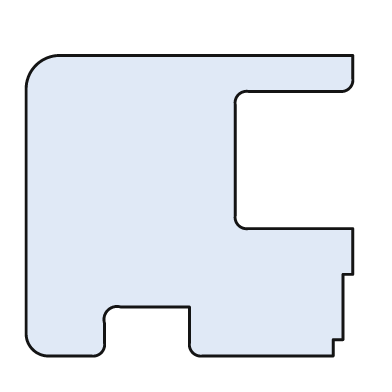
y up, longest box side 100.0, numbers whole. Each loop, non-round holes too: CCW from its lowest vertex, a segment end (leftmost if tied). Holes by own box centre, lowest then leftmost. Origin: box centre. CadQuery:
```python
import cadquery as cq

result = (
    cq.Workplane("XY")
    .moveTo(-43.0, -46.0)
    .lineTo(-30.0, -46.0)
    .threePointArc((-27.0, -45.0), (-26.0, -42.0))
    .lineTo(-26.0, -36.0)
    .threePointArc((-25.0, -32.0), (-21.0, -31.0))
    .lineTo(0.0, -31.0)
    .lineTo(0.0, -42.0)
    .threePointArc((1.0, -45.0), (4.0, -46.0))
    .lineTo(44.0, -46.0)
    .lineTo(44.0, -41.0)
    .lineTo(47.0, -41.0)
    .lineTo(47.0, -21.0)
    .lineTo(50.0, -21.0)
    .lineTo(50.0, -7.0)
    .lineTo(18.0, -7.0)
    .threePointArc((15.0, -6.0), (14.0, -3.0))
    .lineTo(14.0, 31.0)
    .threePointArc((15.0, 34.0), (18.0, 35.0))
    .lineTo(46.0, 35.0)
    .threePointArc((49.0, 36.0), (50.0, 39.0))
    .lineTo(50.0, 46.0)
    .lineTo(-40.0, 46.0)
    .threePointArc((-47.0, 43.0), (-50.0, 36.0))
    .lineTo(-50.0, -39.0)
    .threePointArc((-48.0, -44.0), (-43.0, -46.0))
    .close()
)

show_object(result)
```